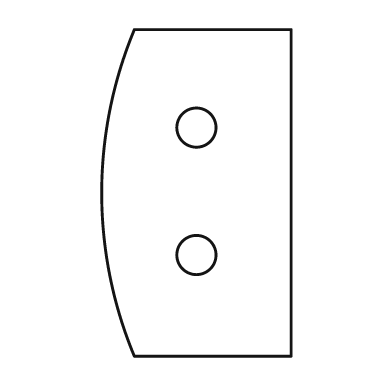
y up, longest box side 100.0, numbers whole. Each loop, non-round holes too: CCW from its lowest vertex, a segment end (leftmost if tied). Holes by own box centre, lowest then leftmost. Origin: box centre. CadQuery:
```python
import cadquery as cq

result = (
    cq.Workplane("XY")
    .moveTo(-19.0, -50.0)
    .lineTo(29.0, -50.0)
    .lineTo(29.0, 50.0)
    .lineTo(-19.0, 50.0)
    .threePointArc((-29.0, 0.0), (-19.0, -50.0))
    .close()
    .moveTo(0.0, -19.0)
    .circle(6.0)
    .moveTo(0.0, 20.0)
    .circle(6.0)
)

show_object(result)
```